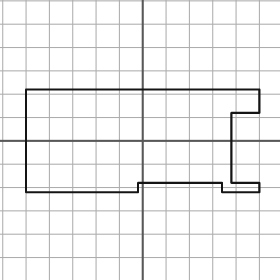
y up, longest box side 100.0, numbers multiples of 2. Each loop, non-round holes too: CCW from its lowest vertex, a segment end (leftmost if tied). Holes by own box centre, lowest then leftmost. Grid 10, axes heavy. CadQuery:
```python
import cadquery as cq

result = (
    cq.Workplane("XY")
    .moveTo(-50.0, -22.0)
    .lineTo(-2.0, -22.0)
    .lineTo(-2.0, -18.0)
    .lineTo(34.0, -18.0)
    .lineTo(34.0, -22.0)
    .lineTo(50.0, -22.0)
    .lineTo(50.0, -18.0)
    .lineTo(38.0, -18.0)
    .lineTo(38.0, 12.0)
    .lineTo(50.0, 12.0)
    .lineTo(50.0, 22.0)
    .lineTo(-50.0, 22.0)
    .close()
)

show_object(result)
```